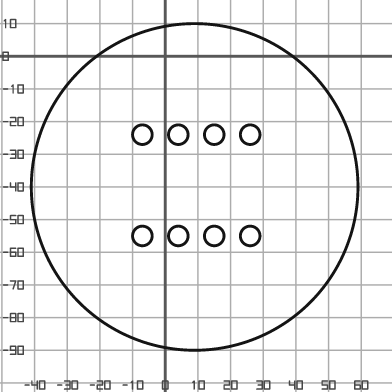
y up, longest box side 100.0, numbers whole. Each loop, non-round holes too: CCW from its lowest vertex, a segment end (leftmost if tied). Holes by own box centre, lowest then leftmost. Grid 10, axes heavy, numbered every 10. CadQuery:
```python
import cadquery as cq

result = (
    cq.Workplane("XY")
    .moveTo(9.0, -40.0)
    .circle(50.0)
    .moveTo(-7.0, -55.0)
    .circle(3.0)
    .moveTo(4.0, -55.0)
    .circle(3.0)
    .moveTo(15.0, -55.0)
    .circle(3.0)
    .moveTo(26.0, -55.0)
    .circle(3.0)
    .moveTo(-7.0, -24.0)
    .circle(3.0)
    .moveTo(4.0, -24.0)
    .circle(3.0)
    .moveTo(15.0, -24.0)
    .circle(3.0)
    .moveTo(26.0, -24.0)
    .circle(3.0)
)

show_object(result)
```